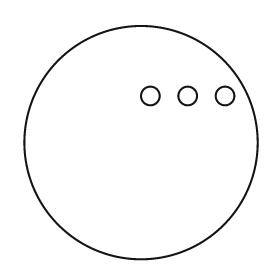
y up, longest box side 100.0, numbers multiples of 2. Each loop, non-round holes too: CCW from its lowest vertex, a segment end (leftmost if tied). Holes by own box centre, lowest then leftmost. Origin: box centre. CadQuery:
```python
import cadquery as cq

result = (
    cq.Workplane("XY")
    .moveTo(0.0, 0.0)
    .circle(50.0)
    .moveTo(4.0, 20.0)
    .circle(4.0)
    .moveTo(20.0, 20.0)
    .circle(4.0)
    .moveTo(36.0, 20.0)
    .circle(4.0)
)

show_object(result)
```